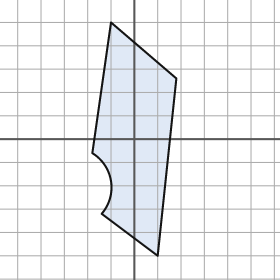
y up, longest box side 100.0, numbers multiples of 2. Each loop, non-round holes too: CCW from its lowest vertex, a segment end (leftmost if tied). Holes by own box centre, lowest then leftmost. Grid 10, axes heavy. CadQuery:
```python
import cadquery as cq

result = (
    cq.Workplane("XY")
    .moveTo(10.0, -50.0)
    .lineTo(18.0, 26.0)
    .lineTo(-10.0, 50.0)
    .lineTo(-18.0, -6.0)
    .threePointArc((-10.0, -18.0), (-14.0, -32.0))
    .close()
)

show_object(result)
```